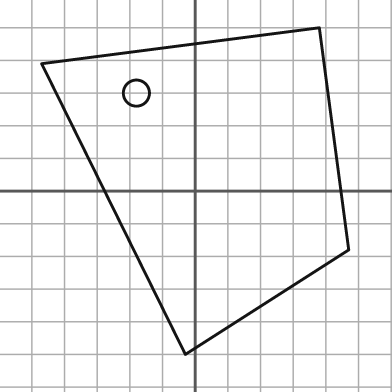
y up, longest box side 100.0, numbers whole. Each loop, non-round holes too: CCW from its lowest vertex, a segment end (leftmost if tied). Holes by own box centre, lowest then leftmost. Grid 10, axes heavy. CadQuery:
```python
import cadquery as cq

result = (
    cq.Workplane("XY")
    .moveTo(-3.0, -50.0)
    .lineTo(47.0, -18.0)
    .lineTo(38.0, 50.0)
    .lineTo(-47.0, 39.0)
    .close()
    .moveTo(-18.0, 30.0)
    .circle(4.0)
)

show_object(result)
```